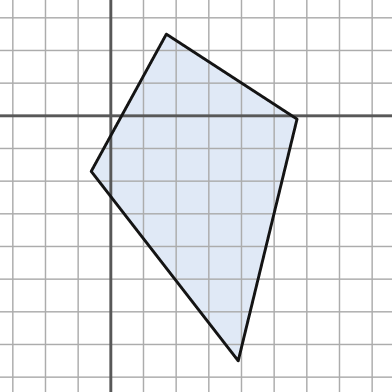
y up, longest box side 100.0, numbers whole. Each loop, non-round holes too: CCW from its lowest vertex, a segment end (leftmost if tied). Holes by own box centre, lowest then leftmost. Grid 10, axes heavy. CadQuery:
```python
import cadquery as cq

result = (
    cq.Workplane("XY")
    .moveTo(39.0, -75.0)
    .lineTo(57.0, -1.0)
    .lineTo(17.0, 25.0)
    .lineTo(-6.0, -17.0)
    .close()
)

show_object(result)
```